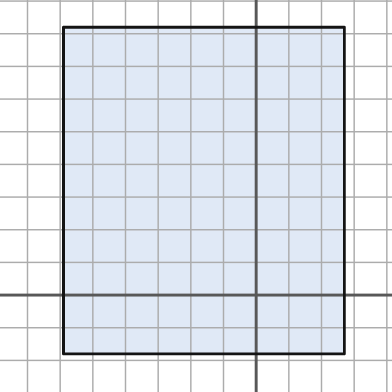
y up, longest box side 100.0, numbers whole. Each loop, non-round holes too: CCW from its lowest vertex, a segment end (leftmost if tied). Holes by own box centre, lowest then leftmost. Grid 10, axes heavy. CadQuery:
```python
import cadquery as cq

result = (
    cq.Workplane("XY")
    .moveTo(-59.0, -18.0)
    .lineTo(27.0, -18.0)
    .lineTo(27.0, 82.0)
    .lineTo(-59.0, 82.0)
    .close()
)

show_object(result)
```